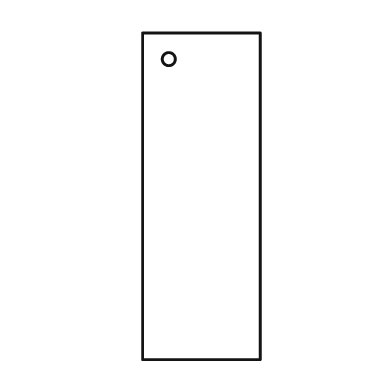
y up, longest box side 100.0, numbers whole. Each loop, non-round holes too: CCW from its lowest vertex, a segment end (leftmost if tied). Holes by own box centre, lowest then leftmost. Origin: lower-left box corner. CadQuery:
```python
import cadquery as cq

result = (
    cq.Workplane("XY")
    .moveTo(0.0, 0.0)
    .lineTo(36.0, 0.0)
    .lineTo(36.0, 100.0)
    .lineTo(0.0, 100.0)
    .close()
    .moveTo(8.0, 92.0)
    .circle(2.0)
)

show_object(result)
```